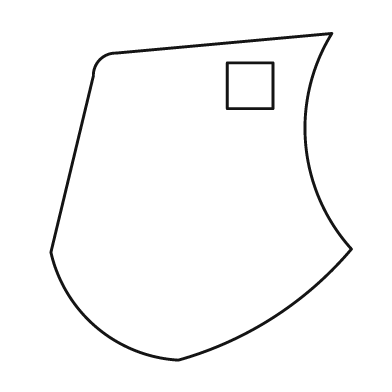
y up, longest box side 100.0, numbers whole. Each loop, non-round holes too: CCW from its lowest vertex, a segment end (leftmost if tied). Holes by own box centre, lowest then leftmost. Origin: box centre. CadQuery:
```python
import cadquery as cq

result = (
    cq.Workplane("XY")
    .moveTo(-7.0, -50.0)
    .threePointArc((22.0, -37.0), (46.0, -16.0))
    .threePointArc((32.0, 16.0), (40.0, 50.0))
    .lineTo(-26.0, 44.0)
    .threePointArc((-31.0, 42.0), (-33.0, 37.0))
    .lineTo(-46.0, -17.0)
    .threePointArc((-32.0, -40.0), (-7.0, -50.0))
    .close()
    .moveTo(8.0, 27.0)
    .lineTo(22.0, 27.0)
    .lineTo(22.0, 41.0)
    .lineTo(8.0, 41.0)
    .close()
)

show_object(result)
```